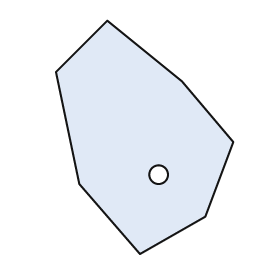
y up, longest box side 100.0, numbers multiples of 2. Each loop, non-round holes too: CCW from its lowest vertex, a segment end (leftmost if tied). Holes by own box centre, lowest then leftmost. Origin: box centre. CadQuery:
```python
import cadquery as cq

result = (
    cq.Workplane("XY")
    .moveTo(-2.0, -50.0)
    .lineTo(26.0, -34.0)
    .lineTo(38.0, -2.0)
    .lineTo(16.0, 24.0)
    .lineTo(-16.0, 50.0)
    .lineTo(-38.0, 28.0)
    .lineTo(-28.0, -20.0)
    .close()
    .moveTo(6.0, -16.0)
    .circle(4.0)
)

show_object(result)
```